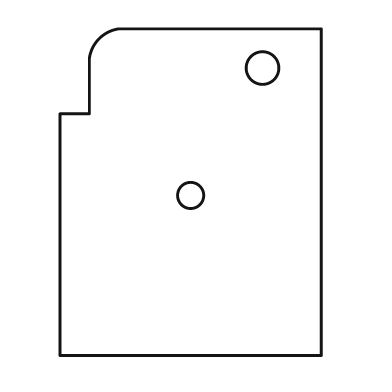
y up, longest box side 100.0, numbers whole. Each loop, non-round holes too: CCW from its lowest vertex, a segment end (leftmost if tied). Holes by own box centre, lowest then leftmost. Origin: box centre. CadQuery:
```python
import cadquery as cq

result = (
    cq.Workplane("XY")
    .moveTo(-40.0, -50.0)
    .lineTo(40.0, -50.0)
    .lineTo(40.0, 50.0)
    .lineTo(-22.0, 50.0)
    .threePointArc((-28.0, 47.0), (-31.0, 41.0))
    .lineTo(-31.0, 24.0)
    .lineTo(-40.0, 24.0)
    .close()
    .moveTo(0.0, -1.0)
    .circle(4.0)
    .moveTo(22.0, 38.0)
    .circle(5.0)
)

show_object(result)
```